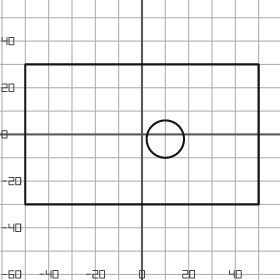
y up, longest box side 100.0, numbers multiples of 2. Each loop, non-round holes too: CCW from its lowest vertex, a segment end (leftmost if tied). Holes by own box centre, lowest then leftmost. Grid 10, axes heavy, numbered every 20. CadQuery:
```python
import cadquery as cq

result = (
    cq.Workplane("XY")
    .moveTo(-50.0, -30.0)
    .lineTo(50.0, -30.0)
    .lineTo(50.0, 30.0)
    .lineTo(-50.0, 30.0)
    .close()
    .moveTo(10.0, -2.0)
    .circle(8.0)
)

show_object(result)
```